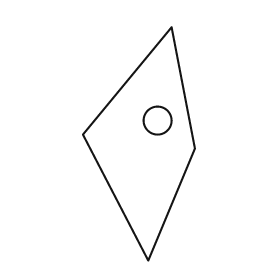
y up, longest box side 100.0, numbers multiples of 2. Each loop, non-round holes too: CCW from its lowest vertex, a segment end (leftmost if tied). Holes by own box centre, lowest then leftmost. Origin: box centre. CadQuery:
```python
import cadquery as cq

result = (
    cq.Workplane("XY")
    .moveTo(4.0, -50.0)
    .lineTo(24.0, -2.0)
    .lineTo(14.0, 50.0)
    .lineTo(-24.0, 4.0)
    .close()
    .moveTo(8.0, 10.0)
    .circle(6.0)
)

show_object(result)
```